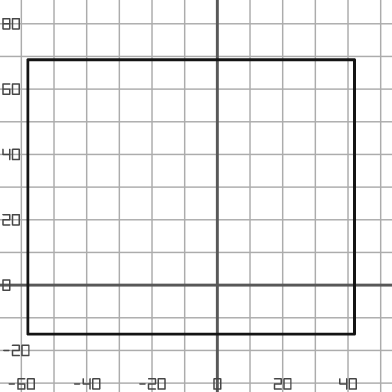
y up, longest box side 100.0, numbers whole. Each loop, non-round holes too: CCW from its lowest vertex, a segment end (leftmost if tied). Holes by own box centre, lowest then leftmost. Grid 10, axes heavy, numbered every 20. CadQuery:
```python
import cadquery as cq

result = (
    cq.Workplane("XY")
    .moveTo(-58.0, -15.0)
    .lineTo(42.0, -15.0)
    .lineTo(42.0, 69.0)
    .lineTo(-58.0, 69.0)
    .close()
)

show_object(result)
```